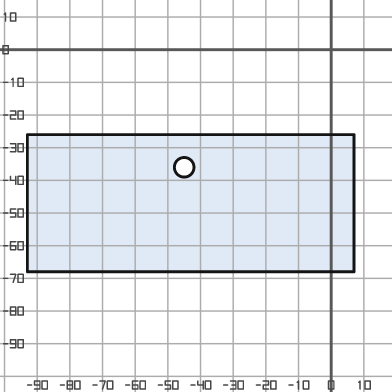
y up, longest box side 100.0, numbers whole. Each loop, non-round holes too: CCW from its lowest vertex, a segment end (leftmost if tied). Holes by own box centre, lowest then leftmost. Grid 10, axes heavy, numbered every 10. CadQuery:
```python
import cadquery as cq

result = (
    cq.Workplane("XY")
    .moveTo(-93.0, -68.0)
    .lineTo(7.0, -68.0)
    .lineTo(7.0, -26.0)
    .lineTo(-93.0, -26.0)
    .close()
    .moveTo(-45.0, -36.0)
    .circle(3.0)
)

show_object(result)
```